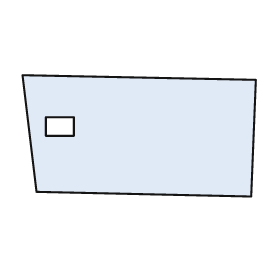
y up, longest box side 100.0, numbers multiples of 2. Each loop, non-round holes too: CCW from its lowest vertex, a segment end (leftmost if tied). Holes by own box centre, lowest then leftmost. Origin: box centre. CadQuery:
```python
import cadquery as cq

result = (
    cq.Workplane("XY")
    .moveTo(48.0, -26.0)
    .lineTo(50.0, 24.0)
    .lineTo(-50.0, 26.0)
    .lineTo(-44.0, -24.0)
    .close()
    .moveTo(-40.0, 0.0)
    .lineTo(-28.0, 0.0)
    .lineTo(-28.0, 8.0)
    .lineTo(-40.0, 8.0)
    .close()
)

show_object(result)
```